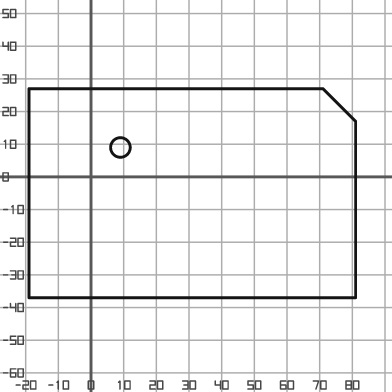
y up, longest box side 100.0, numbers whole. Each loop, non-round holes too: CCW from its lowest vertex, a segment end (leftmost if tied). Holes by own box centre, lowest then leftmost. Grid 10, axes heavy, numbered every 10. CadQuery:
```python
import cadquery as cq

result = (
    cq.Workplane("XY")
    .moveTo(-19.0, -37.0)
    .lineTo(81.0, -37.0)
    .lineTo(81.0, 17.0)
    .lineTo(71.0, 27.0)
    .lineTo(-19.0, 27.0)
    .close()
    .moveTo(9.0, 9.0)
    .circle(3.0)
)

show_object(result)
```